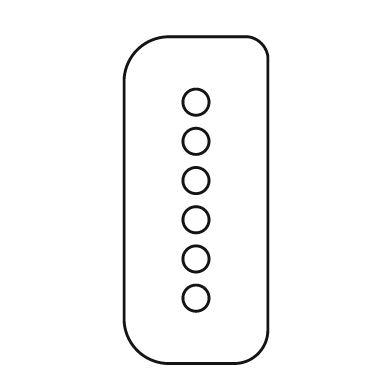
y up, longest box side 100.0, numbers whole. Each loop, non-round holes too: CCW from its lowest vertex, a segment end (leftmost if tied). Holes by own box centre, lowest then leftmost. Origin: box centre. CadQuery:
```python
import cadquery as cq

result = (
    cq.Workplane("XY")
    .moveTo(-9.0, -50.0)
    .lineTo(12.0, -50.0)
    .threePointArc((19.0, -47.0), (22.0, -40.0))
    .lineTo(22.0, 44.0)
    .threePointArc((20.0, 48.0), (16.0, 50.0))
    .lineTo(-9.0, 50.0)
    .threePointArc((-18.0, 46.0), (-22.0, 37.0))
    .lineTo(-22.0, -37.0)
    .threePointArc((-18.0, -46.0), (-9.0, -50.0))
    .close()
    .moveTo(0.0, -30.0)
    .circle(4.0)
    .moveTo(0.0, -18.0)
    .circle(4.0)
    .moveTo(0.0, -6.0)
    .circle(4.0)
    .moveTo(0.0, 6.0)
    .circle(4.0)
    .moveTo(0.0, 18.0)
    .circle(4.0)
    .moveTo(0.0, 30.0)
    .circle(4.0)
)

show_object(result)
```